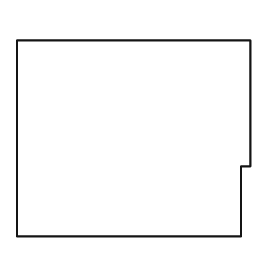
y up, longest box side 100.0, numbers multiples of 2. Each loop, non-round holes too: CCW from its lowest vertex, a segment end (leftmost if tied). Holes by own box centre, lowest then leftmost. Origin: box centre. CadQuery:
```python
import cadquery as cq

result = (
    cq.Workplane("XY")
    .moveTo(-50.0, -42.0)
    .lineTo(46.0, -42.0)
    .lineTo(46.0, -12.0)
    .lineTo(50.0, -12.0)
    .lineTo(50.0, 42.0)
    .lineTo(-50.0, 42.0)
    .close()
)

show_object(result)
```